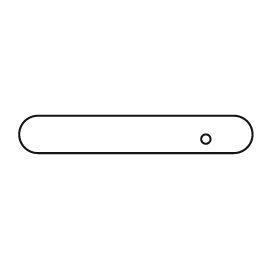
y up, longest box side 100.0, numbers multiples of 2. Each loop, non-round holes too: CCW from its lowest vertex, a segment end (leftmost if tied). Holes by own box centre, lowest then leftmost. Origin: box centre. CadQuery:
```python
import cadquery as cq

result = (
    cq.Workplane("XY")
    .moveTo(-42.0, -8.0)
    .lineTo(42.0, -8.0)
    .threePointArc((50.0, 0.0), (42.0, 8.0))
    .lineTo(-42.0, 8.0)
    .threePointArc((-50.0, 0.0), (-42.0, -8.0))
    .close()
    .moveTo(30.0, -2.0)
    .circle(2.0)
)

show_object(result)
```